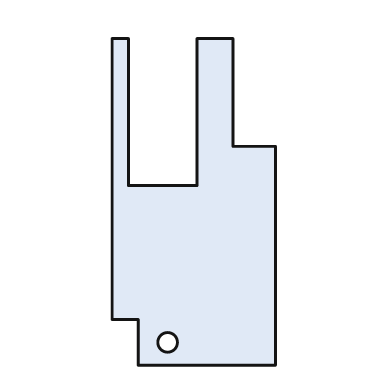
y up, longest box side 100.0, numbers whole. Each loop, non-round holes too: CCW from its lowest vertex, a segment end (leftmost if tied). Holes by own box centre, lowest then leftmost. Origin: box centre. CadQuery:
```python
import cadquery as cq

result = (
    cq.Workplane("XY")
    .moveTo(-17.0, -50.0)
    .lineTo(25.0, -50.0)
    .lineTo(25.0, 17.0)
    .lineTo(12.0, 17.0)
    .lineTo(12.0, 50.0)
    .lineTo(1.0, 50.0)
    .lineTo(1.0, 5.0)
    .lineTo(-20.0, 5.0)
    .lineTo(-20.0, 50.0)
    .lineTo(-25.0, 50.0)
    .lineTo(-25.0, -36.0)
    .lineTo(-17.0, -36.0)
    .close()
    .moveTo(-8.0, -43.0)
    .circle(3.0)
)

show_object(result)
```